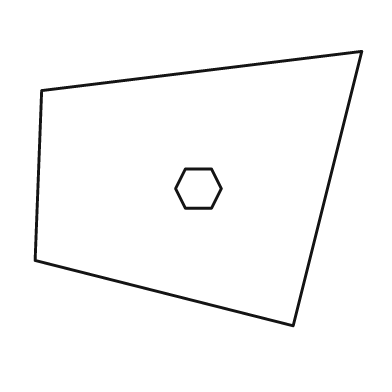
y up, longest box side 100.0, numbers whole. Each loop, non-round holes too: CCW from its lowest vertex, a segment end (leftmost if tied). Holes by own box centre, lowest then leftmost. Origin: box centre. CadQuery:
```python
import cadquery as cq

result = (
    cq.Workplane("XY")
    .moveTo(29.0, -42.0)
    .lineTo(50.0, 42.0)
    .lineTo(-48.0, 30.0)
    .lineTo(-50.0, -22.0)
    .close()
    .moveTo(-4.0, -6.0)
    .lineTo(4.0, -6.0)
    .lineTo(7.0, 0.0)
    .lineTo(4.0, 6.0)
    .lineTo(-4.0, 6.0)
    .lineTo(-7.0, 0.0)
    .close()
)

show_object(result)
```